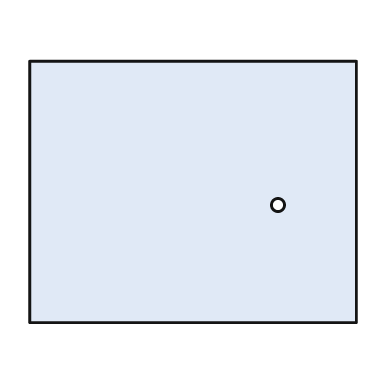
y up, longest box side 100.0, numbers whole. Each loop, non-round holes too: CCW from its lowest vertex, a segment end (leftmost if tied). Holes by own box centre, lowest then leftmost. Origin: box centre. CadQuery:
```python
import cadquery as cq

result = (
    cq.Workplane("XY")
    .moveTo(-50.0, -40.0)
    .lineTo(50.0, -40.0)
    .lineTo(50.0, 40.0)
    .lineTo(-50.0, 40.0)
    .close()
    .moveTo(26.0, -4.0)
    .circle(2.0)
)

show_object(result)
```